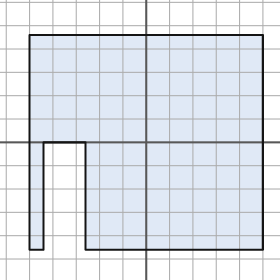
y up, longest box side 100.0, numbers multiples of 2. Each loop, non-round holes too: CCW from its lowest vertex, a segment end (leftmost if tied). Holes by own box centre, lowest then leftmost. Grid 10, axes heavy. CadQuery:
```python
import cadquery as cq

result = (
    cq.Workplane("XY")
    .moveTo(-50.0, -46.0)
    .lineTo(-44.0, -46.0)
    .lineTo(-44.0, 0.0)
    .lineTo(-26.0, 0.0)
    .lineTo(-26.0, -46.0)
    .lineTo(50.0, -46.0)
    .lineTo(50.0, 46.0)
    .lineTo(-50.0, 46.0)
    .close()
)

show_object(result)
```